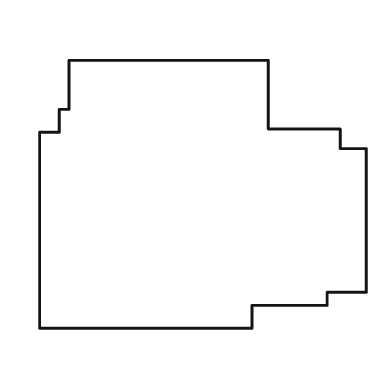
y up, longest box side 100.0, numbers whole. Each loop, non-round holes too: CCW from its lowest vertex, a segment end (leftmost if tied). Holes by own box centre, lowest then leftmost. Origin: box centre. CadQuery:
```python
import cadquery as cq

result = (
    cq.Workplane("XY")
    .moveTo(-50.0, -41.0)
    .lineTo(15.0, -41.0)
    .lineTo(15.0, -34.0)
    .lineTo(38.0, -34.0)
    .lineTo(38.0, -30.0)
    .lineTo(50.0, -30.0)
    .lineTo(50.0, 14.0)
    .lineTo(42.0, 14.0)
    .lineTo(42.0, 20.0)
    .lineTo(20.0, 20.0)
    .lineTo(20.0, 41.0)
    .lineTo(-41.0, 41.0)
    .lineTo(-41.0, 26.0)
    .lineTo(-44.0, 26.0)
    .lineTo(-44.0, 19.0)
    .lineTo(-50.0, 19.0)
    .close()
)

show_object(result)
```